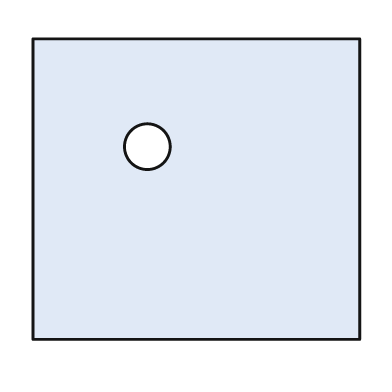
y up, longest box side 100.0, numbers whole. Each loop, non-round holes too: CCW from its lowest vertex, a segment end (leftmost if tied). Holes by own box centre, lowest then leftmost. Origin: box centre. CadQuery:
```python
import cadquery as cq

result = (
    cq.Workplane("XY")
    .moveTo(-50.0, -46.0)
    .lineTo(50.0, -46.0)
    .lineTo(50.0, 46.0)
    .lineTo(-50.0, 46.0)
    .close()
    .moveTo(-15.0, 13.0)
    .circle(7.0)
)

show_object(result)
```